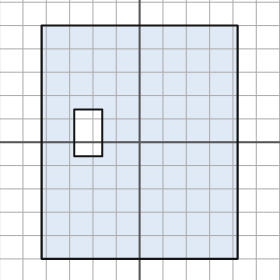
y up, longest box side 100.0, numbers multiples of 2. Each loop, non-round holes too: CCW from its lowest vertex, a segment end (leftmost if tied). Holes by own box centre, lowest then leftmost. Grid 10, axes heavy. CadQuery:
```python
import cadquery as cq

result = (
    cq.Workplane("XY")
    .moveTo(-42.0, -50.0)
    .lineTo(42.0, -50.0)
    .lineTo(42.0, 50.0)
    .lineTo(-42.0, 50.0)
    .close()
    .moveTo(-28.0, -6.0)
    .lineTo(-16.0, -6.0)
    .lineTo(-16.0, 14.0)
    .lineTo(-28.0, 14.0)
    .close()
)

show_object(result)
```